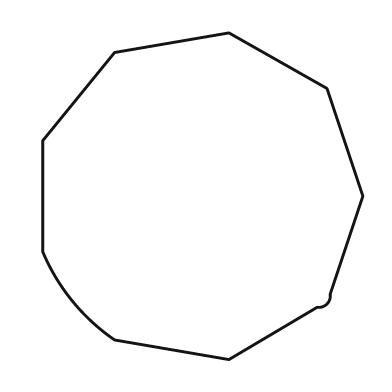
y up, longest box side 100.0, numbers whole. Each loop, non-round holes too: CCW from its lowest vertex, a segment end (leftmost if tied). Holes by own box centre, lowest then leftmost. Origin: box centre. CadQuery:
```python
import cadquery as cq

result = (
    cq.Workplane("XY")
    .moveTo(8.0, -50.0)
    .lineTo(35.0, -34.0)
    .threePointArc((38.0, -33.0), (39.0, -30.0))
    .lineTo(49.0, 0.0)
    .lineTo(38.0, 33.0)
    .lineTo(8.0, 50.0)
    .lineTo(-27.0, 44.0)
    .lineTo(-49.0, 17.0)
    .lineTo(-49.0, -17.0)
    .threePointArc((-40.0, -32.0), (-27.0, -44.0))
    .close()
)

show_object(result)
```